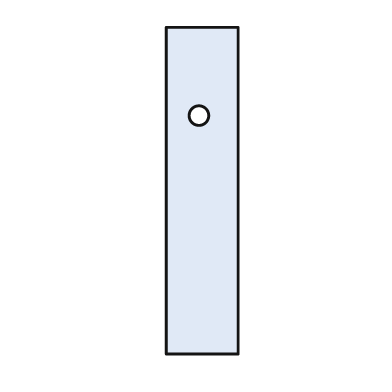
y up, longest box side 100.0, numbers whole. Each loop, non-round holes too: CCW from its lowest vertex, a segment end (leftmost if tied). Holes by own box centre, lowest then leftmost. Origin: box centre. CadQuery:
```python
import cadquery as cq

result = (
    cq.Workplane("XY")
    .moveTo(-11.0, -50.0)
    .lineTo(11.0, -50.0)
    .lineTo(11.0, 50.0)
    .lineTo(-11.0, 50.0)
    .close()
    .moveTo(-1.0, 23.0)
    .circle(3.0)
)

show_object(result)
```